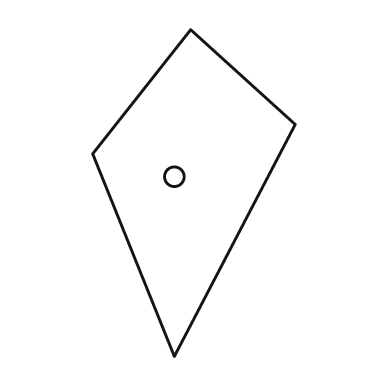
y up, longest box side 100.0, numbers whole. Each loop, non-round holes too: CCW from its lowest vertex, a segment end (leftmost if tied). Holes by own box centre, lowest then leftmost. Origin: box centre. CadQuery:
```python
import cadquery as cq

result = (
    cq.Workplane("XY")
    .moveTo(-6.0, -50.0)
    .lineTo(31.0, 21.0)
    .lineTo(-1.0, 50.0)
    .lineTo(-31.0, 12.0)
    .close()
    .moveTo(-6.0, 5.0)
    .circle(3.0)
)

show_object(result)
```